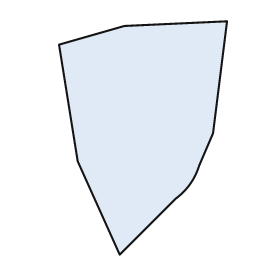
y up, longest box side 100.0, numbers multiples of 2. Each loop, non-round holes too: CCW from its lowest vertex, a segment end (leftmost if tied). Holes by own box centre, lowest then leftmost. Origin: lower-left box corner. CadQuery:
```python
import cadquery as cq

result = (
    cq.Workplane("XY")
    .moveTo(26.0, 0.0)
    .lineTo(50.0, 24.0)
    .threePointArc((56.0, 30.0), (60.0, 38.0))
    .lineTo(66.0, 52.0)
    .lineTo(72.0, 100.0)
    .lineTo(28.0, 98.0)
    .lineTo(0.0, 90.0)
    .lineTo(8.0, 40.0)
    .close()
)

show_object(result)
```